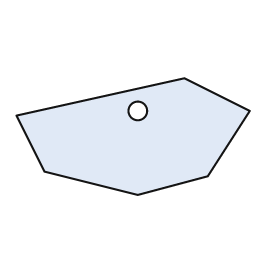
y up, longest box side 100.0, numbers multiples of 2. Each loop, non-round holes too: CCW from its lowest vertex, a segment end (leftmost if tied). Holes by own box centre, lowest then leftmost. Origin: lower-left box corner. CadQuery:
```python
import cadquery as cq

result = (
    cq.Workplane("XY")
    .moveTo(52.0, 0.0)
    .lineTo(82.0, 8.0)
    .lineTo(100.0, 36.0)
    .lineTo(72.0, 50.0)
    .lineTo(0.0, 34.0)
    .lineTo(12.0, 10.0)
    .close()
    .moveTo(52.0, 36.0)
    .circle(4.0)
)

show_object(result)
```